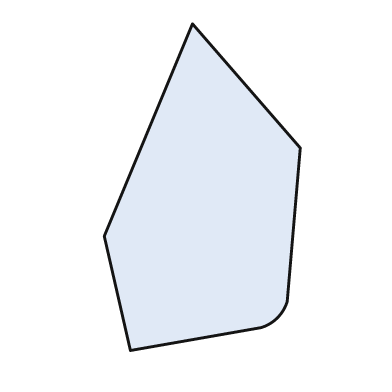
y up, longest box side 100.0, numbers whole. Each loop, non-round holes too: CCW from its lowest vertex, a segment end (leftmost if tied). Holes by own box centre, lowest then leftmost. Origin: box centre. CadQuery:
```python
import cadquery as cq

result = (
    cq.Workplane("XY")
    .moveTo(-22.0, -50.0)
    .lineTo(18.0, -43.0)
    .threePointArc((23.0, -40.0), (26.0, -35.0))
    .lineTo(30.0, 12.0)
    .lineTo(-3.0, 50.0)
    .lineTo(-30.0, -15.0)
    .close()
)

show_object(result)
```